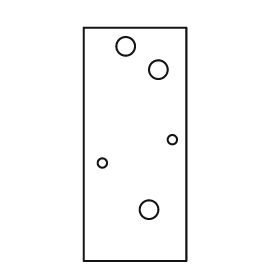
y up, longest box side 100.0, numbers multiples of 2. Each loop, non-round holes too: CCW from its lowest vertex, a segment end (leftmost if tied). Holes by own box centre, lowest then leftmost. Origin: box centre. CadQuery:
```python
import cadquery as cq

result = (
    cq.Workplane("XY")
    .moveTo(-22.0, -50.0)
    .lineTo(22.0, -50.0)
    .lineTo(22.0, 50.0)
    .lineTo(-22.0, 50.0)
    .close()
    .moveTo(6.0, -28.0)
    .circle(4.0)
    .moveTo(-14.0, -8.0)
    .circle(2.0)
    .moveTo(16.0, 2.0)
    .circle(2.0)
    .moveTo(10.0, 32.0)
    .circle(4.0)
    .moveTo(-4.0, 42.0)
    .circle(4.0)
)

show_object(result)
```